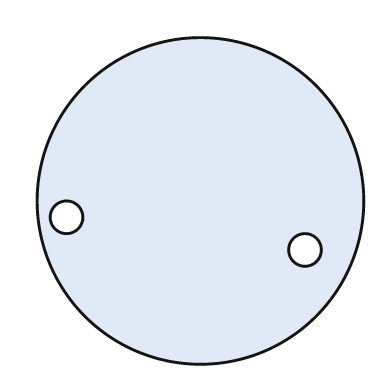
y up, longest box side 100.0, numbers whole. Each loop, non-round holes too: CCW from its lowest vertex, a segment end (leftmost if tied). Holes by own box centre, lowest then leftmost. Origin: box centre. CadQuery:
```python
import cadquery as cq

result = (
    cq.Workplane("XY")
    .moveTo(0.0, 0.0)
    .circle(50.0)
    .moveTo(32.0, -15.0)
    .circle(5.0)
    .moveTo(-41.0, -5.0)
    .circle(5.0)
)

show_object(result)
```